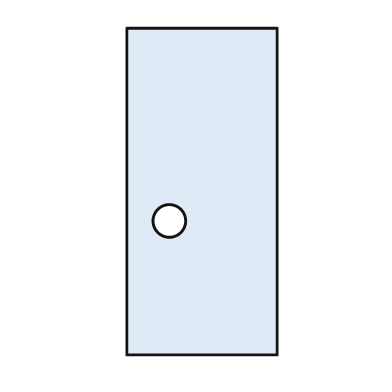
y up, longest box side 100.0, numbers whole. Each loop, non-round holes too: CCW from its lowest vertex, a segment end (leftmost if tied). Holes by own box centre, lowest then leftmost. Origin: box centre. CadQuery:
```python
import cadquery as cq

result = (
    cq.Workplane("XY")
    .moveTo(-23.0, -50.0)
    .lineTo(23.0, -50.0)
    .lineTo(23.0, 50.0)
    .lineTo(-23.0, 50.0)
    .close()
    .moveTo(-10.0, -9.0)
    .circle(5.0)
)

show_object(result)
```